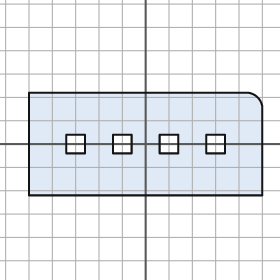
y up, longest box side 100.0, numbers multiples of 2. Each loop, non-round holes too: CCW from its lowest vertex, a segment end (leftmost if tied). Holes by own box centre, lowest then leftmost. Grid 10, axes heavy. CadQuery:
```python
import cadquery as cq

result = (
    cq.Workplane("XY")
    .moveTo(-50.0, -22.0)
    .lineTo(50.0, -22.0)
    .lineTo(50.0, 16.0)
    .threePointArc((48.0, 20.0), (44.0, 22.0))
    .lineTo(-50.0, 22.0)
    .close()
    .moveTo(-34.0, -4.0)
    .lineTo(-26.0, -4.0)
    .lineTo(-26.0, 4.0)
    .lineTo(-34.0, 4.0)
    .close()
    .moveTo(-14.0, -4.0)
    .lineTo(-6.0, -4.0)
    .lineTo(-6.0, 4.0)
    .lineTo(-14.0, 4.0)
    .close()
    .moveTo(6.0, -4.0)
    .lineTo(14.0, -4.0)
    .lineTo(14.0, 4.0)
    .lineTo(6.0, 4.0)
    .close()
    .moveTo(26.0, -4.0)
    .lineTo(34.0, -4.0)
    .lineTo(34.0, 4.0)
    .lineTo(26.0, 4.0)
    .close()
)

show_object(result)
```